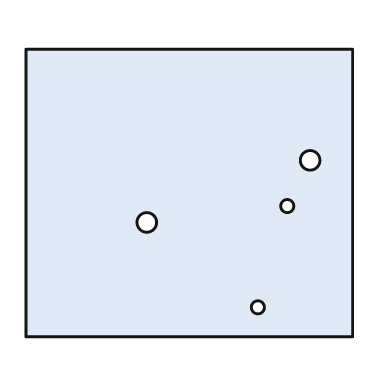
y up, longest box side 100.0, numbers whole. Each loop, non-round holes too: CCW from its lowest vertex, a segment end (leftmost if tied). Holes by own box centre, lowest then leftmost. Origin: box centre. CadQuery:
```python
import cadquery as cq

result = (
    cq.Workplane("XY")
    .moveTo(-50.0, -44.0)
    .lineTo(50.0, -44.0)
    .lineTo(50.0, 44.0)
    .lineTo(-50.0, 44.0)
    .close()
    .moveTo(21.0, -35.0)
    .circle(2.0)
    .moveTo(-13.0, -9.0)
    .circle(3.0)
    .moveTo(30.0, -4.0)
    .circle(2.0)
    .moveTo(37.0, 10.0)
    .circle(3.0)
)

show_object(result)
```